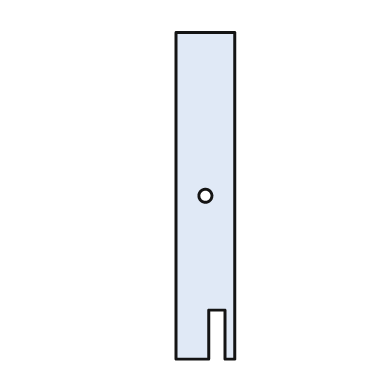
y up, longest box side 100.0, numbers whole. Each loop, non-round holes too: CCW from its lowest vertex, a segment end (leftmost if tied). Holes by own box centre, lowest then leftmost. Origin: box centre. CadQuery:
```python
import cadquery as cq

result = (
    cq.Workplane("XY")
    .moveTo(-9.0, -50.0)
    .lineTo(1.0, -50.0)
    .lineTo(1.0, -35.0)
    .lineTo(6.0, -35.0)
    .lineTo(6.0, -50.0)
    .lineTo(9.0, -50.0)
    .lineTo(9.0, 50.0)
    .lineTo(-9.0, 50.0)
    .close()
    .moveTo(0.0, 0.0)
    .circle(2.0)
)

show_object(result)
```